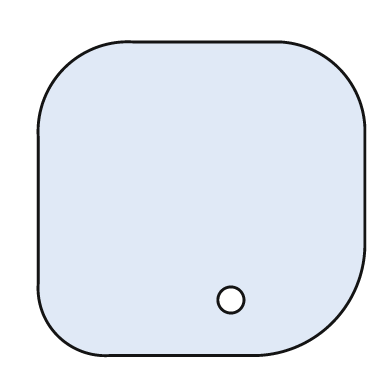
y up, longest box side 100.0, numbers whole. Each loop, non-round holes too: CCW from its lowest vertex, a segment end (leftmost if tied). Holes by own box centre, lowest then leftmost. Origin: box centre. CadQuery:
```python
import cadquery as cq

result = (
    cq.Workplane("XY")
    .moveTo(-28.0, -48.0)
    .lineTo(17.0, -48.0)
    .threePointArc((40.0, -38.0), (50.0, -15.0))
    .lineTo(50.0, 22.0)
    .threePointArc((42.0, 40.0), (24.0, 48.0))
    .lineTo(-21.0, 48.0)
    .threePointArc((-42.0, 40.0), (-50.0, 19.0))
    .lineTo(-50.0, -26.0)
    .threePointArc((-44.0, -42.0), (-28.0, -48.0))
    .close()
    .moveTo(9.0, -31.0)
    .circle(4.0)
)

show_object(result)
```